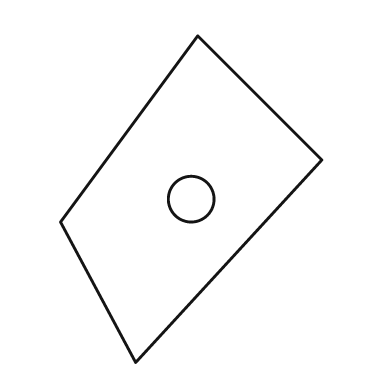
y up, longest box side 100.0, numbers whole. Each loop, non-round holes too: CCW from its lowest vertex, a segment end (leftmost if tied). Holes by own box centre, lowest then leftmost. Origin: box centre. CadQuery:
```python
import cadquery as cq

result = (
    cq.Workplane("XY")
    .moveTo(-17.0, -50.0)
    .lineTo(40.0, 12.0)
    .lineTo(2.0, 50.0)
    .lineTo(-40.0, -7.0)
    .close()
    .moveTo(0.0, 0.0)
    .circle(7.0)
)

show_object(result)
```